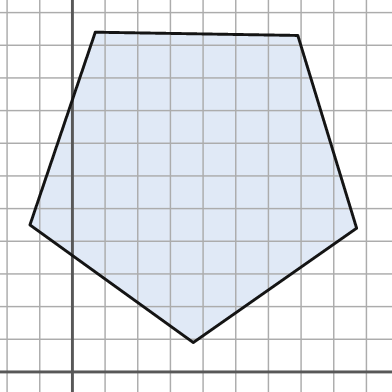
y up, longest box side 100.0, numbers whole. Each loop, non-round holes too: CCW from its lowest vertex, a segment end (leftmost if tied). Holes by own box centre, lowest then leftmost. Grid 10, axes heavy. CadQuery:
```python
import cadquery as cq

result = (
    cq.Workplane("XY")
    .moveTo(37.0, 9.0)
    .lineTo(87.0, 44.0)
    .lineTo(69.0, 103.0)
    .lineTo(7.0, 104.0)
    .lineTo(-13.0, 45.0)
    .close()
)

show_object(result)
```